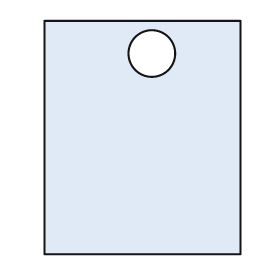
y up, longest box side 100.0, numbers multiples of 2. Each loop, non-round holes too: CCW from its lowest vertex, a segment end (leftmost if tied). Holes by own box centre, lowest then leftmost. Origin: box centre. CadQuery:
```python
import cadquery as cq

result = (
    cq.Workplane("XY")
    .moveTo(-42.0, -50.0)
    .lineTo(42.0, -50.0)
    .lineTo(42.0, 50.0)
    .lineTo(-42.0, 50.0)
    .close()
    .moveTo(4.0, 36.0)
    .circle(10.0)
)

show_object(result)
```